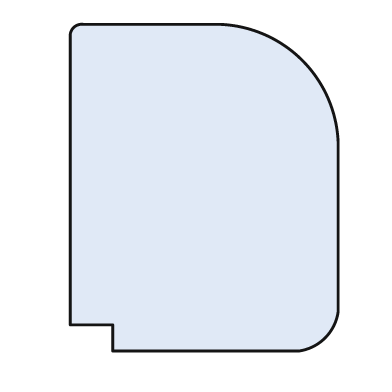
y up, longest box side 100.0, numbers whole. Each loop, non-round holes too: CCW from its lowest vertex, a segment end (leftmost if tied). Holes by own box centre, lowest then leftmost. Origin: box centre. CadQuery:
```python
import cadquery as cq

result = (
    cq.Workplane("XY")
    .moveTo(-28.0, -50.0)
    .lineTo(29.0, -50.0)
    .threePointArc((37.0, -46.0), (41.0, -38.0))
    .lineTo(41.0, 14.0)
    .threePointArc((30.0, 39.0), (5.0, 50.0))
    .lineTo(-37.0, 50.0)
    .threePointArc((-40.0, 49.0), (-41.0, 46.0))
    .lineTo(-41.0, -42.0)
    .lineTo(-28.0, -42.0)
    .close()
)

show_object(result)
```